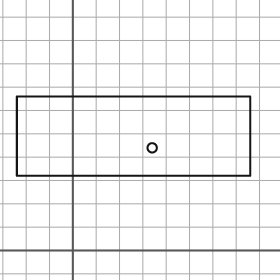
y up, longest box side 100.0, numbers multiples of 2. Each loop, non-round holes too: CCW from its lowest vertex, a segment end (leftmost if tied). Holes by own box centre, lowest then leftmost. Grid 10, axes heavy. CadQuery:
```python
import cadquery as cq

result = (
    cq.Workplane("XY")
    .moveTo(-24.0, 32.0)
    .lineTo(76.0, 32.0)
    .lineTo(76.0, 66.0)
    .lineTo(-24.0, 66.0)
    .close()
    .moveTo(34.0, 44.0)
    .circle(2.0)
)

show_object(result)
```